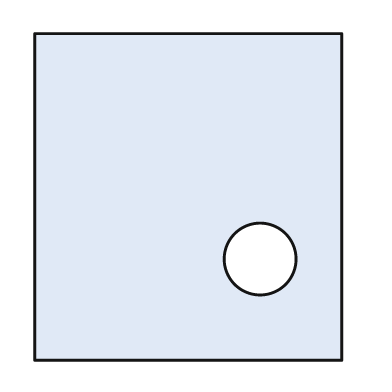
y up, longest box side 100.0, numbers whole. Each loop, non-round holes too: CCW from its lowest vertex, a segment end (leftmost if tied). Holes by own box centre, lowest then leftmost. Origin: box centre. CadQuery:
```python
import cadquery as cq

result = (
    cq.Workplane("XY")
    .moveTo(-47.0, -50.0)
    .lineTo(47.0, -50.0)
    .lineTo(47.0, 50.0)
    .lineTo(-47.0, 50.0)
    .close()
    .moveTo(22.0, -19.0)
    .circle(11.0)
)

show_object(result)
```